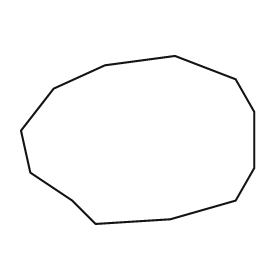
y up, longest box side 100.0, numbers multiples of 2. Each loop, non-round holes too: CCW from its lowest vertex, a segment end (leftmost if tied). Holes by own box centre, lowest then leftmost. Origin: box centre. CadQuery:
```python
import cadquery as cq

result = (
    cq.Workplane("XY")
    .moveTo(-18.0, -36.0)
    .lineTo(14.0, -34.0)
    .lineTo(42.0, -26.0)
    .lineTo(50.0, -12.0)
    .lineTo(50.0, 12.0)
    .lineTo(42.0, 26.0)
    .lineTo(16.0, 36.0)
    .lineTo(-14.0, 32.0)
    .lineTo(-36.0, 22.0)
    .lineTo(-50.0, 4.0)
    .lineTo(-46.0, -14.0)
    .lineTo(-28.0, -26.0)
    .close()
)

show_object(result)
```